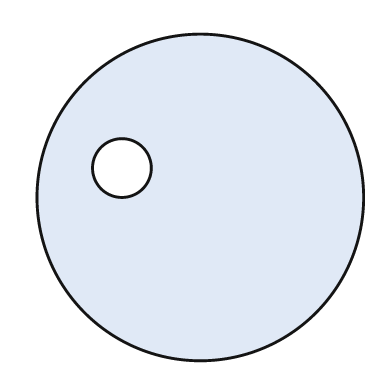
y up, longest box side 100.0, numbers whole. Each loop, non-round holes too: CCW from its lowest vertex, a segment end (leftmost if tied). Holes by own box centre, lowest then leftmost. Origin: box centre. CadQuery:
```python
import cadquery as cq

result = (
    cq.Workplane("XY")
    .moveTo(0.0, 0.0)
    .circle(50.0)
    .moveTo(-24.0, 9.0)
    .circle(9.0)
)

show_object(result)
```